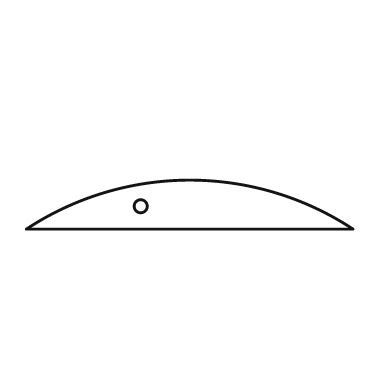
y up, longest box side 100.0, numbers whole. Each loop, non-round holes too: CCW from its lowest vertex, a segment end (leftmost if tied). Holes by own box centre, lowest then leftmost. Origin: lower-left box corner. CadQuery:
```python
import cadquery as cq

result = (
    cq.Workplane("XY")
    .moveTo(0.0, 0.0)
    .lineTo(100.0, 0.0)
    .threePointArc((50.0, 15.0), (0.0, 0.0))
    .close()
    .moveTo(35.0, 7.0)
    .circle(2.0)
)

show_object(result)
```